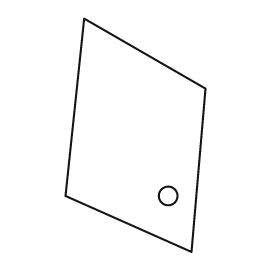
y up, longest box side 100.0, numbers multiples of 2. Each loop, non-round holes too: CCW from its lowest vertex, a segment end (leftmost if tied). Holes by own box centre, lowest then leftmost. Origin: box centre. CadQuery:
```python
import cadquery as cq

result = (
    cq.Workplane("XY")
    .moveTo(24.0, -50.0)
    .lineTo(30.0, 20.0)
    .lineTo(-22.0, 50.0)
    .lineTo(-30.0, -26.0)
    .close()
    .moveTo(14.0, -26.0)
    .circle(4.0)
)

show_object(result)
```